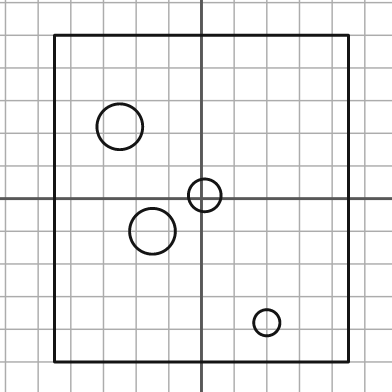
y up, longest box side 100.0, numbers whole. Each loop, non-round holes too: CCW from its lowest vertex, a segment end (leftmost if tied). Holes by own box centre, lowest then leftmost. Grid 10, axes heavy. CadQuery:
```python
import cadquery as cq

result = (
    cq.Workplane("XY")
    .moveTo(-45.0, -50.0)
    .lineTo(45.0, -50.0)
    .lineTo(45.0, 50.0)
    .lineTo(-45.0, 50.0)
    .close()
    .moveTo(20.0, -38.0)
    .circle(4.0)
    .moveTo(-15.0, -10.0)
    .circle(7.0)
    .moveTo(1.0, 1.0)
    .circle(5.0)
    .moveTo(-25.0, 22.0)
    .circle(7.0)
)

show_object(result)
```